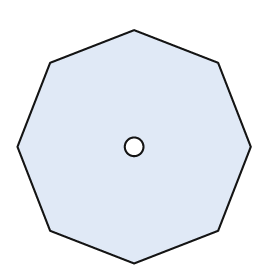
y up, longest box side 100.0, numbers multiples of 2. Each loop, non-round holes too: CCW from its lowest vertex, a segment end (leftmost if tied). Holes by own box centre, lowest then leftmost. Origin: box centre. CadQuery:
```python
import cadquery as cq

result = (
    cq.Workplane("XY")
    .moveTo(0.0, -50.0)
    .lineTo(36.0, -36.0)
    .lineTo(50.0, 0.0)
    .lineTo(36.0, 36.0)
    .lineTo(0.0, 50.0)
    .lineTo(-36.0, 36.0)
    .lineTo(-50.0, 0.0)
    .lineTo(-36.0, -36.0)
    .close()
    .moveTo(0.0, 0.0)
    .circle(4.0)
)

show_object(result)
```